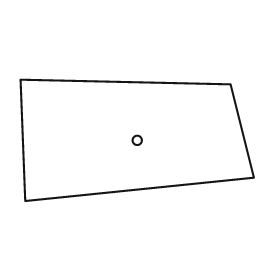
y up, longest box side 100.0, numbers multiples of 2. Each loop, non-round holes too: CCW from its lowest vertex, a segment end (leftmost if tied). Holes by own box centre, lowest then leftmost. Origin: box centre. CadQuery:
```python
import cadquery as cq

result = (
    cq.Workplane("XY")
    .moveTo(-48.0, -26.0)
    .lineTo(50.0, -16.0)
    .lineTo(40.0, 24.0)
    .lineTo(-50.0, 26.0)
    .close()
    .moveTo(0.0, 0.0)
    .circle(2.0)
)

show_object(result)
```